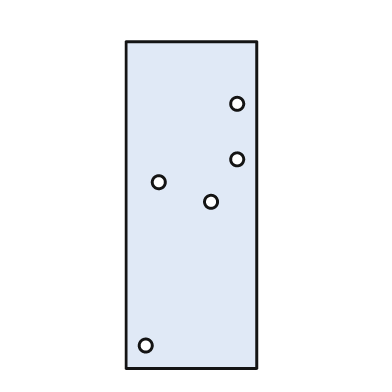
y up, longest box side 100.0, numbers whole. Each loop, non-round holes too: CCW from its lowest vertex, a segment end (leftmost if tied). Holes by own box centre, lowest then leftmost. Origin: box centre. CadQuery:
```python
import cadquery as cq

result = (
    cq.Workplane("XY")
    .moveTo(-20.0, -50.0)
    .lineTo(20.0, -50.0)
    .lineTo(20.0, 50.0)
    .lineTo(-20.0, 50.0)
    .close()
    .moveTo(-14.0, -43.0)
    .circle(2.0)
    .moveTo(6.0, 1.0)
    .circle(2.0)
    .moveTo(-10.0, 7.0)
    .circle(2.0)
    .moveTo(14.0, 14.0)
    .circle(2.0)
    .moveTo(14.0, 31.0)
    .circle(2.0)
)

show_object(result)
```